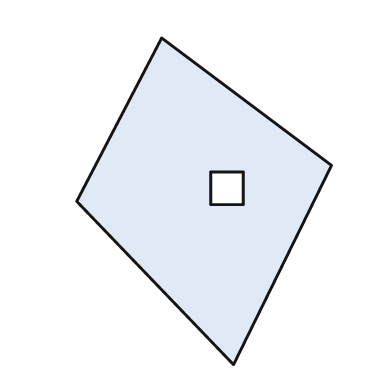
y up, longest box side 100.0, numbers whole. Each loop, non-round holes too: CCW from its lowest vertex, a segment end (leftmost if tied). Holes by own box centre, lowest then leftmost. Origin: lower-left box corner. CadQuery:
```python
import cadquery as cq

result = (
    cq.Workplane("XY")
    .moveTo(48.0, 0.0)
    .lineTo(78.0, 61.0)
    .lineTo(26.0, 100.0)
    .lineTo(0.0, 50.0)
    .close()
    .moveTo(41.0, 49.0)
    .lineTo(51.0, 49.0)
    .lineTo(51.0, 59.0)
    .lineTo(41.0, 59.0)
    .close()
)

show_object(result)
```